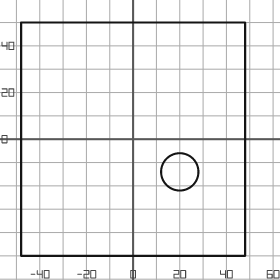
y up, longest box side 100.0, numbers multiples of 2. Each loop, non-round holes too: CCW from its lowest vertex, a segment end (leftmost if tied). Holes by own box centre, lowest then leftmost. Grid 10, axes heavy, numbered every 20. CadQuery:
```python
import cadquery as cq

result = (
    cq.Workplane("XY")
    .moveTo(-48.0, -50.0)
    .lineTo(48.0, -50.0)
    .lineTo(48.0, 50.0)
    .lineTo(-48.0, 50.0)
    .close()
    .moveTo(20.0, -14.0)
    .circle(8.0)
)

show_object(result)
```